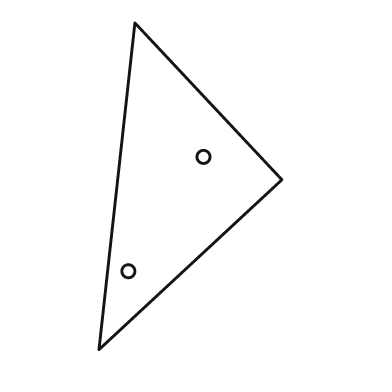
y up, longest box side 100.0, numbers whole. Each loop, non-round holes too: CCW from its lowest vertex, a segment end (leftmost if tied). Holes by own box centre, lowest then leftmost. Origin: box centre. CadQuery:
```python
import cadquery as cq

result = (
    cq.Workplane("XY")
    .moveTo(-28.0, -50.0)
    .lineTo(28.0, 2.0)
    .lineTo(-17.0, 50.0)
    .close()
    .moveTo(-19.0, -26.0)
    .circle(2.0)
    .moveTo(4.0, 9.0)
    .circle(2.0)
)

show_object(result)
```